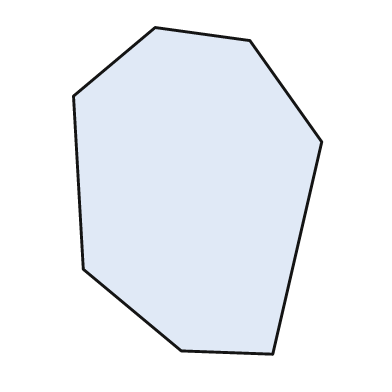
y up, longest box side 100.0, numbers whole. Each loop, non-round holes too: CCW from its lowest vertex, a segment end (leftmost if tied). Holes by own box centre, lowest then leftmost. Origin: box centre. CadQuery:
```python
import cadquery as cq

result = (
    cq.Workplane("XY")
    .moveTo(23.0, -50.0)
    .lineTo(38.0, 15.0)
    .lineTo(16.0, 46.0)
    .lineTo(-13.0, 50.0)
    .lineTo(-38.0, 29.0)
    .lineTo(-35.0, -24.0)
    .lineTo(-5.0, -49.0)
    .close()
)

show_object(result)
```